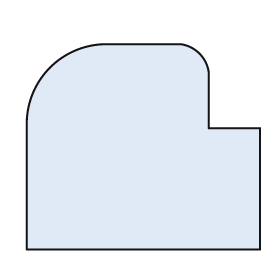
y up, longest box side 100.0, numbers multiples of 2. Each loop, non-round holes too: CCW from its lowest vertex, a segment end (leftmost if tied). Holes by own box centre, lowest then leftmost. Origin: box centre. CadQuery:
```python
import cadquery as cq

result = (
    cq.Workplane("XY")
    .moveTo(-50.0, -44.0)
    .lineTo(50.0, -44.0)
    .lineTo(50.0, 8.0)
    .lineTo(28.0, 8.0)
    .lineTo(28.0, 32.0)
    .threePointArc((24.0, 40.0), (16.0, 44.0))
    .lineTo(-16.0, 44.0)
    .threePointArc((-40.0, 34.0), (-50.0, 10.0))
    .close()
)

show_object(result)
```